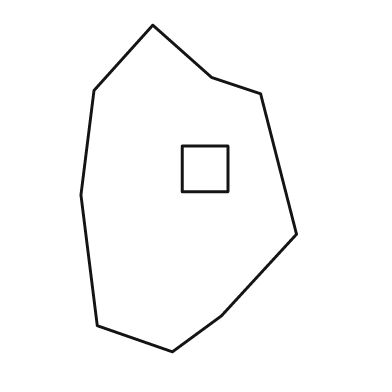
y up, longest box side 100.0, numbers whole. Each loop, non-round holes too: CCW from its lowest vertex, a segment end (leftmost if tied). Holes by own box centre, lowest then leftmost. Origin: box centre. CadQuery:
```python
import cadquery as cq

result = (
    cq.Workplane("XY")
    .moveTo(-5.0, -50.0)
    .lineTo(10.0, -39.0)
    .lineTo(33.0, -14.0)
    .lineTo(22.0, 29.0)
    .lineTo(7.0, 34.0)
    .lineTo(-11.0, 50.0)
    .lineTo(-29.0, 30.0)
    .lineTo(-33.0, -2.0)
    .lineTo(-28.0, -42.0)
    .close()
    .moveTo(-2.0, -1.0)
    .lineTo(12.0, -1.0)
    .lineTo(12.0, 13.0)
    .lineTo(-2.0, 13.0)
    .close()
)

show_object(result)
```